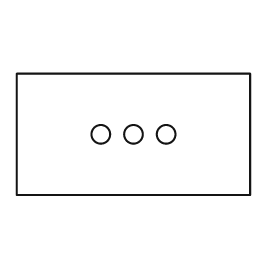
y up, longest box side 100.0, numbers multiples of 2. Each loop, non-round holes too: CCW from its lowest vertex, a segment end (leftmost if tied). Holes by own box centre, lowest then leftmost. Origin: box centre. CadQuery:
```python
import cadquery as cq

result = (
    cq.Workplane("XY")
    .moveTo(-50.0, -26.0)
    .lineTo(50.0, -26.0)
    .lineTo(50.0, 26.0)
    .lineTo(-50.0, 26.0)
    .close()
    .moveTo(-14.0, 0.0)
    .circle(4.0)
    .moveTo(0.0, 0.0)
    .circle(4.0)
    .moveTo(14.0, 0.0)
    .circle(4.0)
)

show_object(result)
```